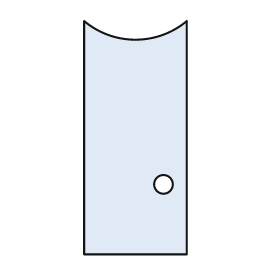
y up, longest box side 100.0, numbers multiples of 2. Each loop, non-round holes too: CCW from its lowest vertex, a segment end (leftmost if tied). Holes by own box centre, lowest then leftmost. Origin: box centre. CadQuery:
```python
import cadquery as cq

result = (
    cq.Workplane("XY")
    .moveTo(-22.0, -50.0)
    .lineTo(22.0, -50.0)
    .lineTo(22.0, 50.0)
    .threePointArc((0.0, 42.0), (-22.0, 50.0))
    .close()
    .moveTo(12.0, -20.0)
    .circle(4.0)
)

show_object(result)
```